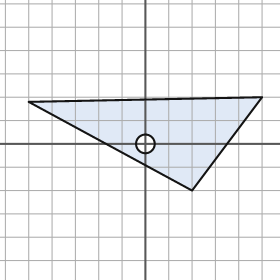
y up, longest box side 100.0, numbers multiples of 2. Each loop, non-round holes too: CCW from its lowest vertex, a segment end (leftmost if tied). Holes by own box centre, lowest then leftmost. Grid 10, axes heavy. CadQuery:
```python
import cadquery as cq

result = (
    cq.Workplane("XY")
    .moveTo(20.0, -20.0)
    .lineTo(50.0, 20.0)
    .lineTo(-50.0, 18.0)
    .close()
    .moveTo(0.0, 0.0)
    .circle(4.0)
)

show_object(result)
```